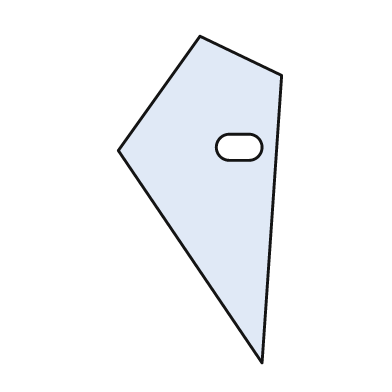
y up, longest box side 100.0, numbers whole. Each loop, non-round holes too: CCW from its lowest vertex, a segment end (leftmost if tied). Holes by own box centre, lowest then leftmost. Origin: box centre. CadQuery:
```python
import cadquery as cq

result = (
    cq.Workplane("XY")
    .moveTo(19.0, -50.0)
    .lineTo(25.0, 38.0)
    .lineTo(0.0, 50.0)
    .lineTo(-25.0, 15.0)
    .close()
    .moveTo(9.0, 12.0)
    .lineTo(15.0, 12.0)
    .threePointArc((19.0, 16.0), (15.0, 20.0))
    .lineTo(9.0, 20.0)
    .threePointArc((5.0, 16.0), (9.0, 12.0))
    .close()
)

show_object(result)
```